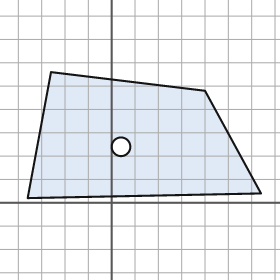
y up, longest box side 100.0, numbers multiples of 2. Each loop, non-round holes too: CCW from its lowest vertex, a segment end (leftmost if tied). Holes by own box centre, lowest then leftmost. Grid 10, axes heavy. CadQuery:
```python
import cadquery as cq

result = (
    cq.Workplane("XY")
    .moveTo(-36.0, 2.0)
    .lineTo(64.0, 4.0)
    .lineTo(40.0, 48.0)
    .lineTo(-26.0, 56.0)
    .close()
    .moveTo(4.0, 24.0)
    .circle(4.0)
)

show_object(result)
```